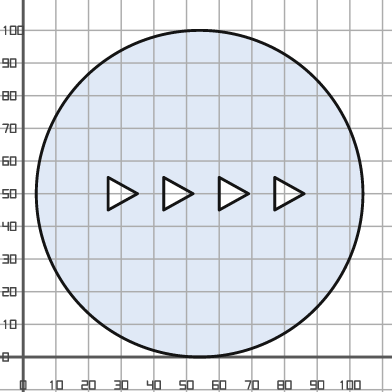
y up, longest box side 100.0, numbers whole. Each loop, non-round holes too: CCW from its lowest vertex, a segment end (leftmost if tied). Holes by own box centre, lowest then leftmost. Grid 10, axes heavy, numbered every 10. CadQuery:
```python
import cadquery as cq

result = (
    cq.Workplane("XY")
    .moveTo(54.0, 50.0)
    .circle(50.0)
    .moveTo(26.0, 45.0)
    .lineTo(35.0, 50.0)
    .lineTo(26.0, 55.0)
    .close()
    .moveTo(43.0, 45.0)
    .lineTo(52.0, 50.0)
    .lineTo(43.0, 55.0)
    .close()
    .moveTo(60.0, 45.0)
    .lineTo(69.0, 50.0)
    .lineTo(60.0, 55.0)
    .close()
    .moveTo(77.0, 45.0)
    .lineTo(86.0, 50.0)
    .lineTo(77.0, 55.0)
    .close()
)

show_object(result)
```